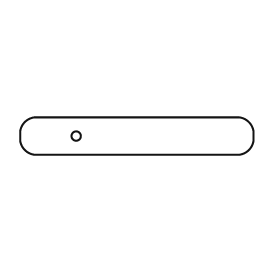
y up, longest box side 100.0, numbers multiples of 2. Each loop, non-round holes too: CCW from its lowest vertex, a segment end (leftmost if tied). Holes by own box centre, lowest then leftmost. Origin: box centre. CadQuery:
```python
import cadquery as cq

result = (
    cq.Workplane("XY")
    .moveTo(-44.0, -8.0)
    .lineTo(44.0, -8.0)
    .threePointArc((48.0, -6.0), (50.0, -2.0))
    .lineTo(50.0, 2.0)
    .threePointArc((48.0, 6.0), (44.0, 8.0))
    .lineTo(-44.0, 8.0)
    .threePointArc((-48.0, 6.0), (-50.0, 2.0))
    .lineTo(-50.0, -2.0)
    .threePointArc((-48.0, -6.0), (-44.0, -8.0))
    .close()
    .moveTo(-26.0, 0.0)
    .circle(2.0)
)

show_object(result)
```